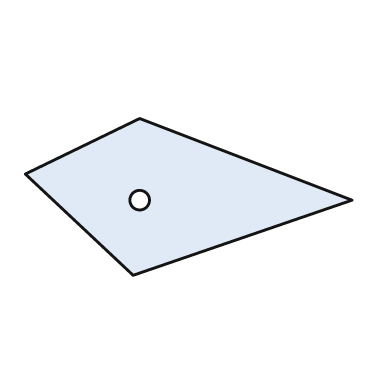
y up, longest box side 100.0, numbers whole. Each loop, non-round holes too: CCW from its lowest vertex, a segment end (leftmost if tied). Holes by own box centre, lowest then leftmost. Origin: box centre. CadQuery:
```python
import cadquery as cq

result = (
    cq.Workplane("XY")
    .moveTo(-17.0, -24.0)
    .lineTo(50.0, -1.0)
    .lineTo(-15.0, 24.0)
    .lineTo(-50.0, 7.0)
    .close()
    .moveTo(-15.0, -1.0)
    .circle(3.0)
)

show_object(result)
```